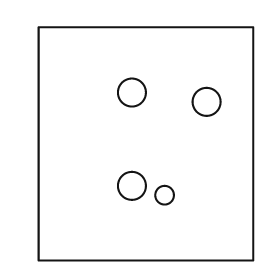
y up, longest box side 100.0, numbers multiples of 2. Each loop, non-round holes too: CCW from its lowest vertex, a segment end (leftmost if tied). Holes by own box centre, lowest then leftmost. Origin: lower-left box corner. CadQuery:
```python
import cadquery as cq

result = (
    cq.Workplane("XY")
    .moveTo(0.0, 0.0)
    .lineTo(92.0, 0.0)
    .lineTo(92.0, 100.0)
    .lineTo(0.0, 100.0)
    .close()
    .moveTo(54.0, 28.0)
    .circle(4.0)
    .moveTo(40.0, 32.0)
    .circle(6.0)
    .moveTo(72.0, 68.0)
    .circle(6.0)
    .moveTo(40.0, 72.0)
    .circle(6.0)
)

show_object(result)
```